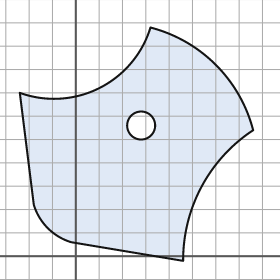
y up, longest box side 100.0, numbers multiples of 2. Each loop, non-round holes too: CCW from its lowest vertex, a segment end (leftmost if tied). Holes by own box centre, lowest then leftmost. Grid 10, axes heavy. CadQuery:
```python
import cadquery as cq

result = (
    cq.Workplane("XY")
    .moveTo(46.0, -2.0)
    .threePointArc((54.0, 30.0), (76.0, 54.0))
    .threePointArc((60.0, 82.0), (32.0, 98.0))
    .threePointArc((10.0, 72.0), (-24.0, 70.0))
    .lineTo(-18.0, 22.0)
    .threePointArc((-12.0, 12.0), (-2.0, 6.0))
    .close()
    .moveTo(28.0, 56.0)
    .circle(6.0)
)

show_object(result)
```